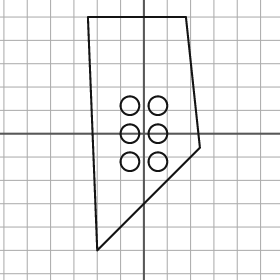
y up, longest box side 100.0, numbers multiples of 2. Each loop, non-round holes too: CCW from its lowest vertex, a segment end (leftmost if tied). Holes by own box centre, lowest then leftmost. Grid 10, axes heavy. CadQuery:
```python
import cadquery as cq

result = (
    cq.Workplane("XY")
    .moveTo(-20.0, -50.0)
    .lineTo(24.0, -6.0)
    .lineTo(18.0, 50.0)
    .lineTo(-24.0, 50.0)
    .close()
    .moveTo(-6.0, -12.0)
    .circle(4.0)
    .moveTo(6.0, -12.0)
    .circle(4.0)
    .moveTo(-6.0, 0.0)
    .circle(4.0)
    .moveTo(6.0, 0.0)
    .circle(4.0)
    .moveTo(-6.0, 12.0)
    .circle(4.0)
    .moveTo(6.0, 12.0)
    .circle(4.0)
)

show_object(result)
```